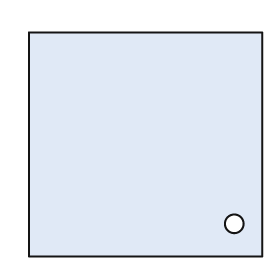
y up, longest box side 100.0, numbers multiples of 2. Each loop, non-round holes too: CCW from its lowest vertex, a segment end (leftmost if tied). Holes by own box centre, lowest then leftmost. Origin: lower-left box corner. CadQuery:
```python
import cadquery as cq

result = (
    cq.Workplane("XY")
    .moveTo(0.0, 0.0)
    .lineTo(100.0, 0.0)
    .lineTo(100.0, 96.0)
    .lineTo(0.0, 96.0)
    .close()
    .moveTo(88.0, 14.0)
    .circle(4.0)
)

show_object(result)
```